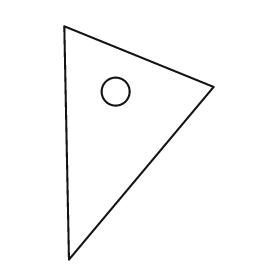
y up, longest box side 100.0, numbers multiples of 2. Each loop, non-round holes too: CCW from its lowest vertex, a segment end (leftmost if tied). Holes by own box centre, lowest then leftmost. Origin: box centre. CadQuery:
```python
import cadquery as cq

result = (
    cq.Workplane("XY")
    .moveTo(-30.0, -50.0)
    .lineTo(32.0, 24.0)
    .lineTo(-32.0, 50.0)
    .close()
    .moveTo(-10.0, 22.0)
    .circle(6.0)
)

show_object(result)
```